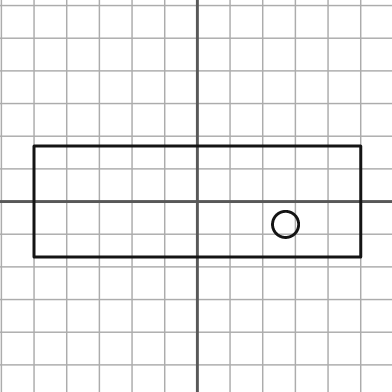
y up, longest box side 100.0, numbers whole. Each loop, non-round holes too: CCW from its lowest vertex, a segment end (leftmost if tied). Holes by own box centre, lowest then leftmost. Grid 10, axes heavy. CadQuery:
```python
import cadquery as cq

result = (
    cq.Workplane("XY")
    .moveTo(-50.0, -17.0)
    .lineTo(50.0, -17.0)
    .lineTo(50.0, 17.0)
    .lineTo(-50.0, 17.0)
    .close()
    .moveTo(27.0, -7.0)
    .circle(4.0)
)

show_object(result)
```